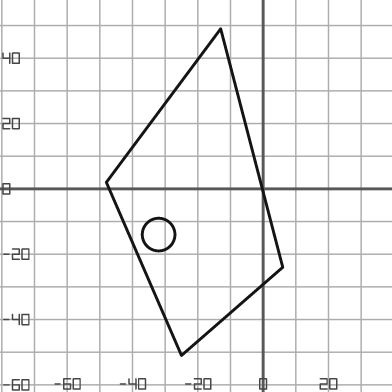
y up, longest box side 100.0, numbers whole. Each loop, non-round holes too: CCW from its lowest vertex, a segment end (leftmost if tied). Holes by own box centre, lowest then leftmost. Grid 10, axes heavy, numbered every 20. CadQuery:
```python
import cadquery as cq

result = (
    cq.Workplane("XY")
    .moveTo(-25.0, -51.0)
    .lineTo(6.0, -24.0)
    .lineTo(-13.0, 49.0)
    .lineTo(-48.0, 2.0)
    .close()
    .moveTo(-32.0, -14.0)
    .circle(5.0)
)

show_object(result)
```